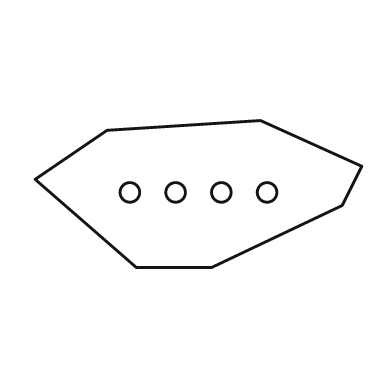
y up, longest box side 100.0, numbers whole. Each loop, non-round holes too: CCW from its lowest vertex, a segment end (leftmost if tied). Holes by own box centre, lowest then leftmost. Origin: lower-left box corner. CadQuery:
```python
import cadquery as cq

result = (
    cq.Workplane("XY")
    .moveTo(31.0, 0.0)
    .lineTo(54.0, 0.0)
    .lineTo(94.0, 19.0)
    .lineTo(100.0, 31.0)
    .lineTo(69.0, 45.0)
    .lineTo(22.0, 42.0)
    .lineTo(0.0, 27.0)
    .close()
    .moveTo(29.0, 23.0)
    .circle(3.0)
    .moveTo(43.0, 23.0)
    .circle(3.0)
    .moveTo(57.0, 23.0)
    .circle(3.0)
    .moveTo(71.0, 23.0)
    .circle(3.0)
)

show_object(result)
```